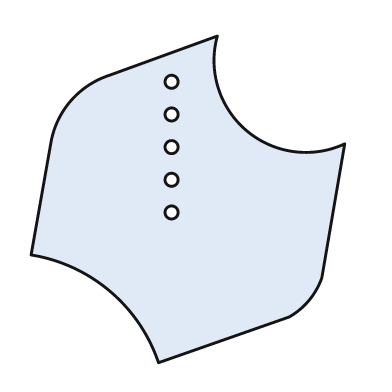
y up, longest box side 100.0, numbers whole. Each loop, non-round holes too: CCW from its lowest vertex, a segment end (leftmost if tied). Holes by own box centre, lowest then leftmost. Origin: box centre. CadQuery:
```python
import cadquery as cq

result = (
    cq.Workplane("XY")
    .moveTo(-9.0, -50.0)
    .lineTo(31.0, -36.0)
    .threePointArc((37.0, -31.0), (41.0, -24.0))
    .lineTo(48.0, 17.0)
    .threePointArc((18.0, 21.0), (9.0, 50.0))
    .lineTo(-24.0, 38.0)
    .threePointArc((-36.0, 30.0), (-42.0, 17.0))
    .lineTo(-48.0, -17.0)
    .threePointArc((-24.0, -28.0), (-9.0, -50.0))
    .close()
    .moveTo(-5.0, -4.0)
    .circle(2.0)
    .moveTo(-5.0, 6.0)
    .circle(2.0)
    .moveTo(-5.0, 16.0)
    .circle(2.0)
    .moveTo(-5.0, 26.0)
    .circle(2.0)
    .moveTo(-5.0, 36.0)
    .circle(2.0)
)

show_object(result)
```